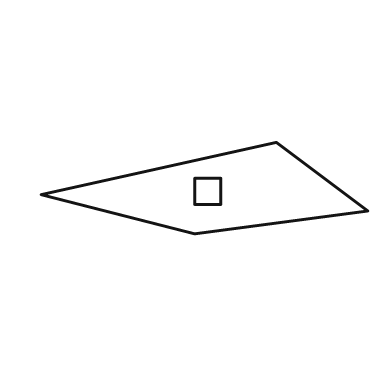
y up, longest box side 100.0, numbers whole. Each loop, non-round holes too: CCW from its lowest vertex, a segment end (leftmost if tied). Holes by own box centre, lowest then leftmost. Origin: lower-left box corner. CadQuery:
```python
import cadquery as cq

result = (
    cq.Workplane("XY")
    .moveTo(47.0, 0.0)
    .lineTo(100.0, 7.0)
    .lineTo(72.0, 28.0)
    .lineTo(0.0, 12.0)
    .close()
    .moveTo(47.0, 9.0)
    .lineTo(55.0, 9.0)
    .lineTo(55.0, 17.0)
    .lineTo(47.0, 17.0)
    .close()
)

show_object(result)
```